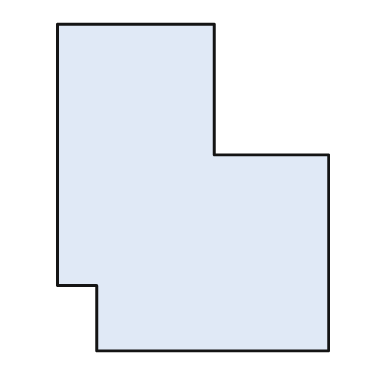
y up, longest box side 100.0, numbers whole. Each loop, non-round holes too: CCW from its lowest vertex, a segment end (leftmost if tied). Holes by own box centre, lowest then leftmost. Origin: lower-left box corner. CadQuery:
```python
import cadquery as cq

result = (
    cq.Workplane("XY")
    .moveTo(12.0, 0.0)
    .lineTo(83.0, 0.0)
    .lineTo(83.0, 60.0)
    .lineTo(48.0, 60.0)
    .lineTo(48.0, 100.0)
    .lineTo(0.0, 100.0)
    .lineTo(0.0, 20.0)
    .lineTo(12.0, 20.0)
    .close()
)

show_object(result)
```